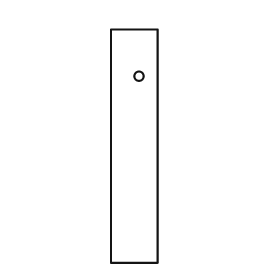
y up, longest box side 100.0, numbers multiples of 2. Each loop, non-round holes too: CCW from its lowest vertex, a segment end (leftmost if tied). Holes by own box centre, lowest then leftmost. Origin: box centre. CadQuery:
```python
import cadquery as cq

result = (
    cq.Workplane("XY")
    .moveTo(-10.0, -50.0)
    .lineTo(10.0, -50.0)
    .lineTo(10.0, 50.0)
    .lineTo(-10.0, 50.0)
    .close()
    .moveTo(2.0, 30.0)
    .circle(2.0)
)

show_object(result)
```